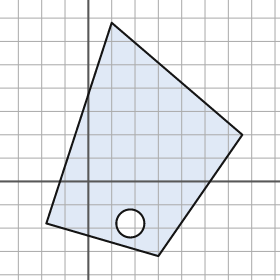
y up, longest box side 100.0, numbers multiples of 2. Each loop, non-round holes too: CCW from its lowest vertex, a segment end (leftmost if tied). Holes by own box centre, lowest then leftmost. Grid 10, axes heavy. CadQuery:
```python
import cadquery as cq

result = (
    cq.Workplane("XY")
    .moveTo(30.0, -32.0)
    .lineTo(66.0, 20.0)
    .lineTo(10.0, 68.0)
    .lineTo(-18.0, -18.0)
    .close()
    .moveTo(18.0, -18.0)
    .circle(6.0)
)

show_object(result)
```